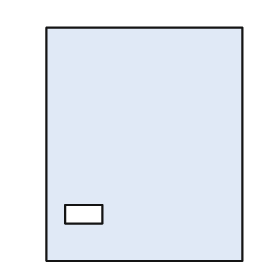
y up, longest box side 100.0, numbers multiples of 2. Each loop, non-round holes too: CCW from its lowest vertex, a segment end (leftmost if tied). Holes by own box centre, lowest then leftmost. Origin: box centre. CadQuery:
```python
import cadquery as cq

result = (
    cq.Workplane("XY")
    .moveTo(-42.0, -50.0)
    .lineTo(42.0, -50.0)
    .lineTo(42.0, 50.0)
    .lineTo(-42.0, 50.0)
    .close()
    .moveTo(-34.0, -34.0)
    .lineTo(-18.0, -34.0)
    .lineTo(-18.0, -26.0)
    .lineTo(-34.0, -26.0)
    .close()
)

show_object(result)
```